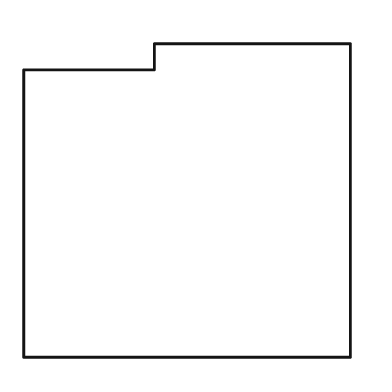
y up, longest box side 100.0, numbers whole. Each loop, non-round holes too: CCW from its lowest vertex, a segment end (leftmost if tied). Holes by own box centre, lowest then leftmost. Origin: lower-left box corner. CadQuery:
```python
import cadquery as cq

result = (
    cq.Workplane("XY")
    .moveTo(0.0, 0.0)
    .lineTo(100.0, 0.0)
    .lineTo(100.0, 96.0)
    .lineTo(40.0, 96.0)
    .lineTo(40.0, 88.0)
    .lineTo(0.0, 88.0)
    .close()
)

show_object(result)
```